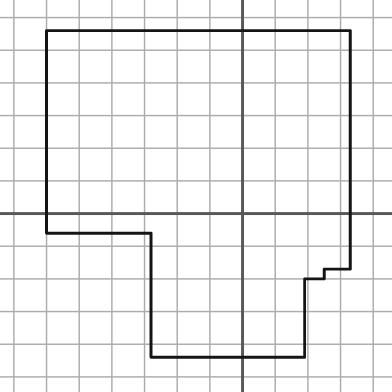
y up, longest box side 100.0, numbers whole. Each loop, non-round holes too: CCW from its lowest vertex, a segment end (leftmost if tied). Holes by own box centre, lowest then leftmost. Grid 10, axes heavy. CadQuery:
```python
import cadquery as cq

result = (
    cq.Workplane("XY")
    .moveTo(-28.0, -44.0)
    .lineTo(19.0, -44.0)
    .lineTo(19.0, -20.0)
    .lineTo(25.0, -20.0)
    .lineTo(25.0, -17.0)
    .lineTo(33.0, -17.0)
    .lineTo(33.0, 56.0)
    .lineTo(-60.0, 56.0)
    .lineTo(-60.0, -6.0)
    .lineTo(-28.0, -6.0)
    .close()
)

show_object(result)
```